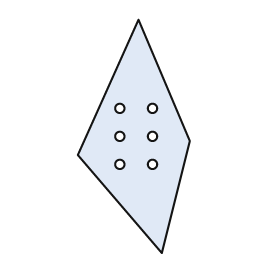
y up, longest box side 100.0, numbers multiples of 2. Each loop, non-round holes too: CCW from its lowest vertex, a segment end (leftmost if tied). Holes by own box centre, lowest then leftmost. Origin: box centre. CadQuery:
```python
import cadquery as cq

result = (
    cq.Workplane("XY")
    .moveTo(12.0, -50.0)
    .lineTo(24.0, -2.0)
    .lineTo(2.0, 50.0)
    .lineTo(-24.0, -8.0)
    .close()
    .moveTo(-6.0, -12.0)
    .circle(2.0)
    .moveTo(8.0, -12.0)
    .circle(2.0)
    .moveTo(-6.0, 0.0)
    .circle(2.0)
    .moveTo(8.0, 0.0)
    .circle(2.0)
    .moveTo(-6.0, 12.0)
    .circle(2.0)
    .moveTo(8.0, 12.0)
    .circle(2.0)
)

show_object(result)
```